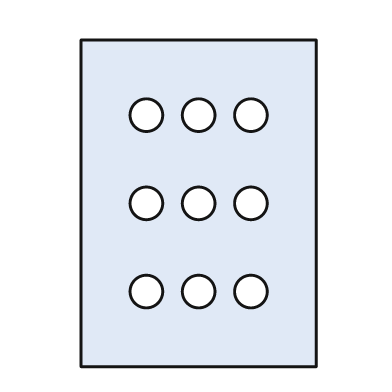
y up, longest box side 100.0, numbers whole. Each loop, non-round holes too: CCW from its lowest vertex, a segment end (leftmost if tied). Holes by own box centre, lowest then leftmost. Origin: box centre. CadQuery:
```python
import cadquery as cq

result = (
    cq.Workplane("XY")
    .moveTo(-36.0, -50.0)
    .lineTo(36.0, -50.0)
    .lineTo(36.0, 50.0)
    .lineTo(-36.0, 50.0)
    .close()
    .moveTo(-16.0, -27.0)
    .circle(5.0)
    .moveTo(0.0, -27.0)
    .circle(5.0)
    .moveTo(16.0, -27.0)
    .circle(5.0)
    .moveTo(-16.0, 0.0)
    .circle(5.0)
    .moveTo(0.0, 0.0)
    .circle(5.0)
    .moveTo(16.0, 0.0)
    .circle(5.0)
    .moveTo(-16.0, 27.0)
    .circle(5.0)
    .moveTo(0.0, 27.0)
    .circle(5.0)
    .moveTo(16.0, 27.0)
    .circle(5.0)
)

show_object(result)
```